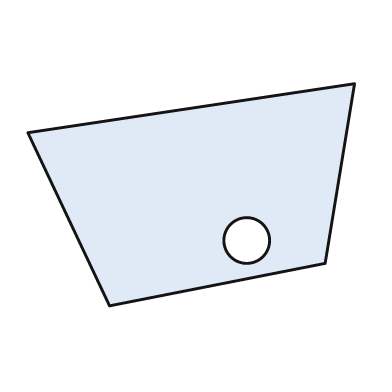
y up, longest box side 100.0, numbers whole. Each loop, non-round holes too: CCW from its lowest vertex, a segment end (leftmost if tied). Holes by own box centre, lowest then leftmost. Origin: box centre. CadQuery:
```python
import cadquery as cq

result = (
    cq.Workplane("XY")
    .moveTo(-25.0, -34.0)
    .lineTo(41.0, -21.0)
    .lineTo(50.0, 34.0)
    .lineTo(-50.0, 19.0)
    .close()
    .moveTo(17.0, -14.0)
    .circle(7.0)
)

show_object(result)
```